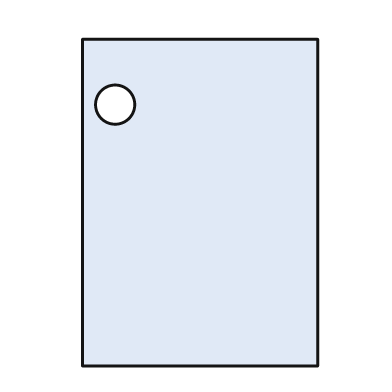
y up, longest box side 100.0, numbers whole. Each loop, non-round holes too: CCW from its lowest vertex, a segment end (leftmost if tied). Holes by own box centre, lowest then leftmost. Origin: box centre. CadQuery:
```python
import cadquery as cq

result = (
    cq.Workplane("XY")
    .moveTo(-36.0, -50.0)
    .lineTo(36.0, -50.0)
    .lineTo(36.0, 50.0)
    .lineTo(-36.0, 50.0)
    .close()
    .moveTo(-26.0, 30.0)
    .circle(6.0)
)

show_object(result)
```